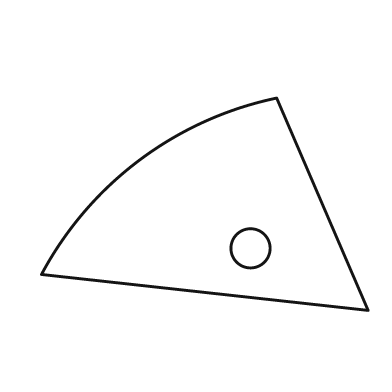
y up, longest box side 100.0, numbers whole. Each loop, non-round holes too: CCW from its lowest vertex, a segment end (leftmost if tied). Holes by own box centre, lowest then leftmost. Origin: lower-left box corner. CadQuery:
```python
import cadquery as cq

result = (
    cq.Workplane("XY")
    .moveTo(100.0, 0.0)
    .lineTo(72.0, 65.0)
    .threePointArc((30.0, 46.0), (0.0, 11.0))
    .close()
    .moveTo(64.0, 19.0)
    .circle(6.0)
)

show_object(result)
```